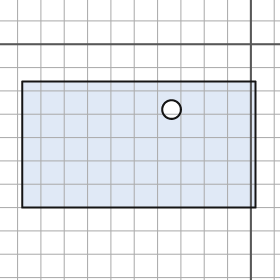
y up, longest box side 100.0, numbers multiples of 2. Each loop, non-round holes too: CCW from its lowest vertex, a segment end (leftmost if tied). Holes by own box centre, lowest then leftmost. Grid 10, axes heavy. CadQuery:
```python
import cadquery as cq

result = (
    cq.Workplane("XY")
    .moveTo(-98.0, -70.0)
    .lineTo(2.0, -70.0)
    .lineTo(2.0, -16.0)
    .lineTo(-98.0, -16.0)
    .close()
    .moveTo(-34.0, -28.0)
    .circle(4.0)
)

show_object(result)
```